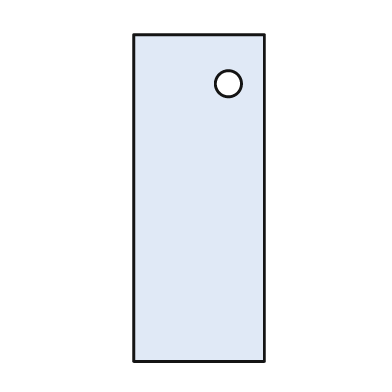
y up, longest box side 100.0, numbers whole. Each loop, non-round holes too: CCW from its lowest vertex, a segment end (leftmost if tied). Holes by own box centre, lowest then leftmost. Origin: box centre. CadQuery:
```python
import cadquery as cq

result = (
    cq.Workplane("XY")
    .moveTo(-20.0, -50.0)
    .lineTo(20.0, -50.0)
    .lineTo(20.0, 50.0)
    .lineTo(-20.0, 50.0)
    .close()
    .moveTo(9.0, 35.0)
    .circle(4.0)
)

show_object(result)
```